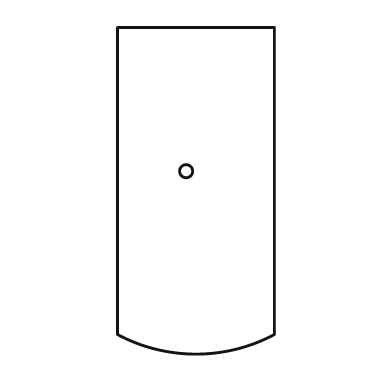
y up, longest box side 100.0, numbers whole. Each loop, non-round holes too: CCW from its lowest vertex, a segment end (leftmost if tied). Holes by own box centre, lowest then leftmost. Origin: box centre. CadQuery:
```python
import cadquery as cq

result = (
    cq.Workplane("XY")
    .moveTo(-24.0, -44.0)
    .threePointArc((0.0, -50.0), (24.0, -44.0))
    .lineTo(24.0, 50.0)
    .lineTo(-24.0, 50.0)
    .close()
    .moveTo(-3.0, 6.0)
    .circle(2.0)
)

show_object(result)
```